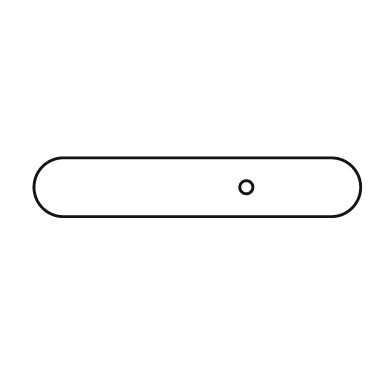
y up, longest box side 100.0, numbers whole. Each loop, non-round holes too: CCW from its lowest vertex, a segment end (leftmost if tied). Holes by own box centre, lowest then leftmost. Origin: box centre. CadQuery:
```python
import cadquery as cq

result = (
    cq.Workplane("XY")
    .moveTo(-41.0, -9.0)
    .lineTo(41.0, -9.0)
    .threePointArc((50.0, 0.0), (41.0, 9.0))
    .lineTo(-41.0, 9.0)
    .threePointArc((-50.0, 0.0), (-41.0, -9.0))
    .close()
    .moveTo(15.0, 0.0)
    .circle(2.0)
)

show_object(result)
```